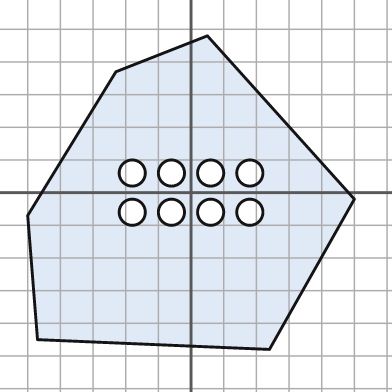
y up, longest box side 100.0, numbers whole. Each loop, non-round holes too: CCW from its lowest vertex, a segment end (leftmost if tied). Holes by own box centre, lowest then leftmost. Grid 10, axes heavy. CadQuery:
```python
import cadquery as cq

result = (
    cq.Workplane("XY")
    .moveTo(24.0, -48.0)
    .lineTo(50.0, -2.0)
    .lineTo(5.0, 48.0)
    .lineTo(-23.0, 37.0)
    .lineTo(-50.0, -7.0)
    .lineTo(-47.0, -45.0)
    .close()
    .moveTo(-18.0, -6.0)
    .circle(4.0)
    .moveTo(-6.0, -6.0)
    .circle(4.0)
    .moveTo(6.0, -6.0)
    .circle(4.0)
    .moveTo(18.0, -6.0)
    .circle(4.0)
    .moveTo(-18.0, 6.0)
    .circle(4.0)
    .moveTo(-6.0, 6.0)
    .circle(4.0)
    .moveTo(6.0, 6.0)
    .circle(4.0)
    .moveTo(18.0, 6.0)
    .circle(4.0)
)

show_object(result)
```